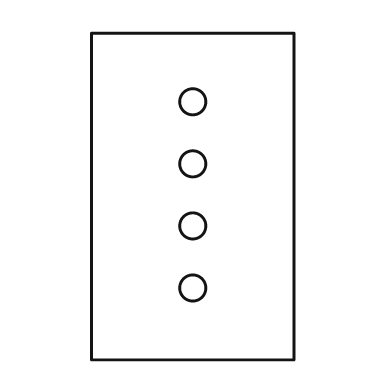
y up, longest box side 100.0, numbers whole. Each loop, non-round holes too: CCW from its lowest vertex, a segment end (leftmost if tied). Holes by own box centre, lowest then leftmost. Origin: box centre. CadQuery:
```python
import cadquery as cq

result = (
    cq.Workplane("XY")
    .moveTo(-31.0, -50.0)
    .lineTo(31.0, -50.0)
    .lineTo(31.0, 50.0)
    .lineTo(-31.0, 50.0)
    .close()
    .moveTo(0.0, -28.0)
    .circle(4.0)
    .moveTo(0.0, -9.0)
    .circle(4.0)
    .moveTo(0.0, 10.0)
    .circle(4.0)
    .moveTo(0.0, 29.0)
    .circle(4.0)
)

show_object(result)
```